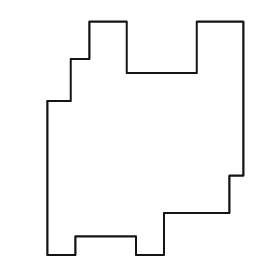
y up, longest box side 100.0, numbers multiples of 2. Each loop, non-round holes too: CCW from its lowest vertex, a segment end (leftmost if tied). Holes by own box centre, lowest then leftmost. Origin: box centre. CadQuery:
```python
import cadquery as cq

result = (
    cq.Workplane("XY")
    .moveTo(-42.0, -50.0)
    .lineTo(-30.0, -50.0)
    .lineTo(-30.0, -42.0)
    .lineTo(-4.0, -42.0)
    .lineTo(-4.0, -50.0)
    .lineTo(8.0, -50.0)
    .lineTo(8.0, -32.0)
    .lineTo(36.0, -32.0)
    .lineTo(36.0, -16.0)
    .lineTo(42.0, -16.0)
    .lineTo(42.0, 50.0)
    .lineTo(22.0, 50.0)
    .lineTo(22.0, 28.0)
    .lineTo(-8.0, 28.0)
    .lineTo(-8.0, 50.0)
    .lineTo(-24.0, 50.0)
    .lineTo(-24.0, 34.0)
    .lineTo(-32.0, 34.0)
    .lineTo(-32.0, 16.0)
    .lineTo(-42.0, 16.0)
    .close()
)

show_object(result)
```